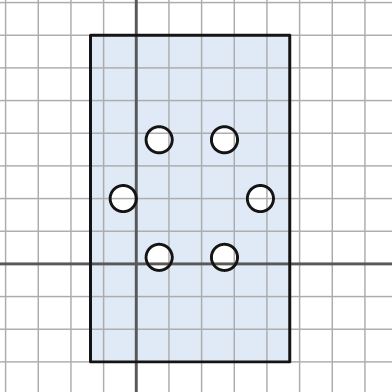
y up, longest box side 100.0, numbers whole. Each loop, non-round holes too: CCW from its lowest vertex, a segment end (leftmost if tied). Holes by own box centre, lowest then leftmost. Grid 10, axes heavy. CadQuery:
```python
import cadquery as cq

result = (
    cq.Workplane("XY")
    .moveTo(-14.0, -30.0)
    .lineTo(47.0, -30.0)
    .lineTo(47.0, 70.0)
    .lineTo(-14.0, 70.0)
    .close()
    .moveTo(7.0, 2.0)
    .circle(4.0)
    .moveTo(27.0, 2.0)
    .circle(4.0)
    .moveTo(-4.0, 20.0)
    .circle(4.0)
    .moveTo(38.0, 20.0)
    .circle(4.0)
    .moveTo(7.0, 38.0)
    .circle(4.0)
    .moveTo(27.0, 38.0)
    .circle(4.0)
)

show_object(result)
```